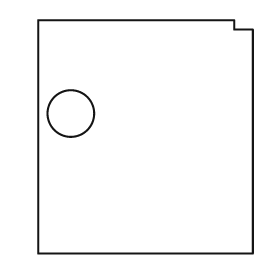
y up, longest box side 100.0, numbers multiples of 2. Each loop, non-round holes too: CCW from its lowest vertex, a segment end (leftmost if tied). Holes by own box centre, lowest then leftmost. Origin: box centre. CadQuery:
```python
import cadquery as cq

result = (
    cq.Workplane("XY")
    .moveTo(-46.0, -50.0)
    .lineTo(46.0, -50.0)
    .lineTo(46.0, 46.0)
    .lineTo(38.0, 46.0)
    .lineTo(38.0, 50.0)
    .lineTo(-46.0, 50.0)
    .close()
    .moveTo(-32.0, 10.0)
    .circle(10.0)
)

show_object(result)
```